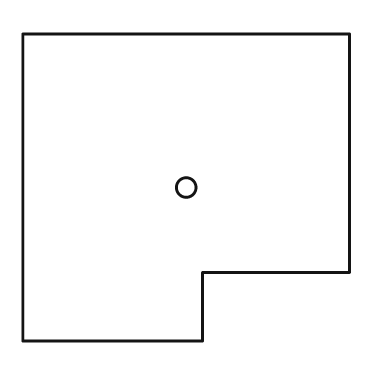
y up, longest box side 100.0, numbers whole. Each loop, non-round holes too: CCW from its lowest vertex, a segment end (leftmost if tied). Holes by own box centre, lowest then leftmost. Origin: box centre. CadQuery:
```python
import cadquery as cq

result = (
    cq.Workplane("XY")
    .moveTo(-50.0, -47.0)
    .lineTo(5.0, -47.0)
    .lineTo(5.0, -26.0)
    .lineTo(50.0, -26.0)
    .lineTo(50.0, 47.0)
    .lineTo(-50.0, 47.0)
    .close()
    .moveTo(0.0, 0.0)
    .circle(3.0)
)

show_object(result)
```